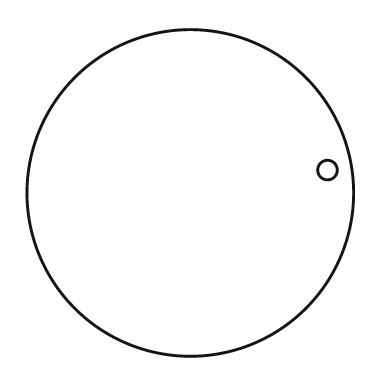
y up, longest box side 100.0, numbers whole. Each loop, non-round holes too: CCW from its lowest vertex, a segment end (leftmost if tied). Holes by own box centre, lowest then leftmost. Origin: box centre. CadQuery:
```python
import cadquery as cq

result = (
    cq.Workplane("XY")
    .moveTo(0.0, 0.0)
    .circle(50.0)
    .moveTo(42.0, 7.0)
    .circle(3.0)
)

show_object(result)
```